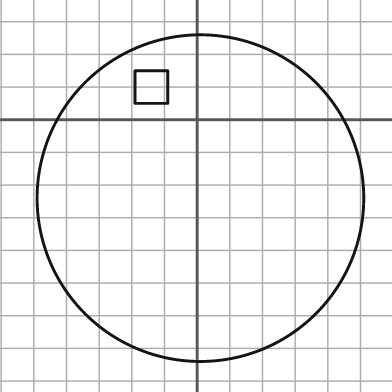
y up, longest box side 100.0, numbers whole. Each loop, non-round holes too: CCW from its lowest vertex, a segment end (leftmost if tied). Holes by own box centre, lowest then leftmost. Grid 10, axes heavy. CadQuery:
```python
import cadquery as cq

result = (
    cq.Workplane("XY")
    .moveTo(1.0, -24.0)
    .circle(50.0)
    .moveTo(-19.0, 5.0)
    .lineTo(-9.0, 5.0)
    .lineTo(-9.0, 15.0)
    .lineTo(-19.0, 15.0)
    .close()
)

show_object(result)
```